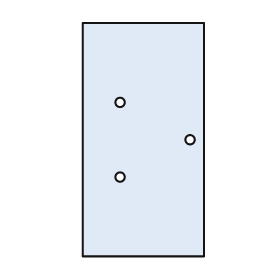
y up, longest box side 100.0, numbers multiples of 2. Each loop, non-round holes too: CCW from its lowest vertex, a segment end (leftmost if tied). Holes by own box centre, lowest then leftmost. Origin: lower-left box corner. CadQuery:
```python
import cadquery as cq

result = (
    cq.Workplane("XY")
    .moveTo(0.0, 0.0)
    .lineTo(52.0, 0.0)
    .lineTo(52.0, 100.0)
    .lineTo(0.0, 100.0)
    .close()
    .moveTo(16.0, 34.0)
    .circle(2.0)
    .moveTo(46.0, 50.0)
    .circle(2.0)
    .moveTo(16.0, 66.0)
    .circle(2.0)
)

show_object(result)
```